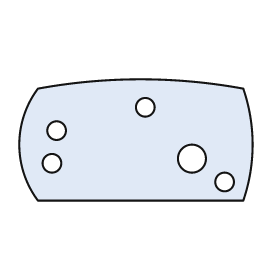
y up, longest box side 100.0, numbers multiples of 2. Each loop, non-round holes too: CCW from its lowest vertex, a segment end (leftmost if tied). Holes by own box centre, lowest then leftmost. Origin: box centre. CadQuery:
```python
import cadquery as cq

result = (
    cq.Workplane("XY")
    .moveTo(-42.0, -26.0)
    .lineTo(46.0, -26.0)
    .threePointArc((50.0, -2.0), (46.0, 22.0))
    .threePointArc((2.0, 26.0), (-42.0, 22.0))
    .threePointArc((-50.0, -2.0), (-42.0, -26.0))
    .close()
    .moveTo(38.0, -18.0)
    .circle(4.0)
    .moveTo(-36.0, -10.0)
    .circle(4.0)
    .moveTo(24.0, -8.0)
    .circle(6.0)
    .moveTo(-34.0, 4.0)
    .circle(4.0)
    .moveTo(4.0, 14.0)
    .circle(4.0)
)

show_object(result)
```